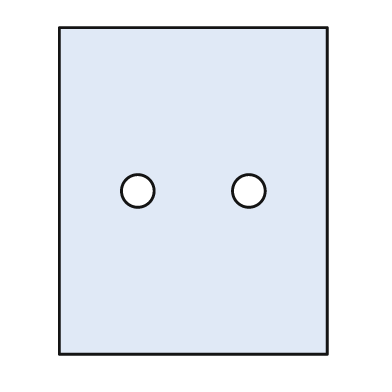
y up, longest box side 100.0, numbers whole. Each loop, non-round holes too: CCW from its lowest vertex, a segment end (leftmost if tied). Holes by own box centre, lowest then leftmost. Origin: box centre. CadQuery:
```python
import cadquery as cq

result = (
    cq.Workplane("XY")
    .moveTo(-41.0, -50.0)
    .lineTo(41.0, -50.0)
    .lineTo(41.0, 50.0)
    .lineTo(-41.0, 50.0)
    .close()
    .moveTo(-17.0, 0.0)
    .circle(5.0)
    .moveTo(17.0, 0.0)
    .circle(5.0)
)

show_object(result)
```